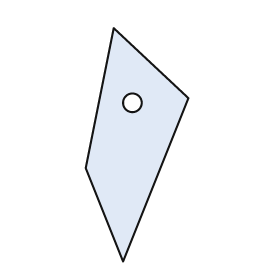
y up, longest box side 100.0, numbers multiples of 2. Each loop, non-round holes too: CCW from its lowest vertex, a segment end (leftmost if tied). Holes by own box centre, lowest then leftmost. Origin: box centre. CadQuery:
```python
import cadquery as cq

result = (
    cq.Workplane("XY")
    .moveTo(-6.0, -50.0)
    .lineTo(22.0, 20.0)
    .lineTo(-10.0, 50.0)
    .lineTo(-22.0, -10.0)
    .close()
    .moveTo(-2.0, 18.0)
    .circle(4.0)
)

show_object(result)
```